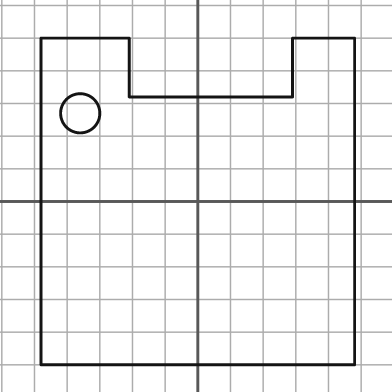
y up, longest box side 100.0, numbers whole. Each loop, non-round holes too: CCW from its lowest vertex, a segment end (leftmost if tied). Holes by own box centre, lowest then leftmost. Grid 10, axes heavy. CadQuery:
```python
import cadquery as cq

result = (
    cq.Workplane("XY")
    .moveTo(-48.0, -50.0)
    .lineTo(48.0, -50.0)
    .lineTo(48.0, 50.0)
    .lineTo(29.0, 50.0)
    .lineTo(29.0, 32.0)
    .lineTo(-21.0, 32.0)
    .lineTo(-21.0, 50.0)
    .lineTo(-48.0, 50.0)
    .close()
    .moveTo(-36.0, 27.0)
    .circle(6.0)
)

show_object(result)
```